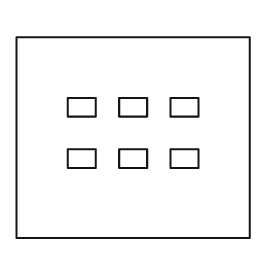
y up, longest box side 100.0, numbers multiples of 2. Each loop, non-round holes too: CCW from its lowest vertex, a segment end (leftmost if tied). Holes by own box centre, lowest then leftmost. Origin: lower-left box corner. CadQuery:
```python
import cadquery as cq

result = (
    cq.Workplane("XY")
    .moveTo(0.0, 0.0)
    .lineTo(100.0, 0.0)
    .lineTo(100.0, 86.0)
    .lineTo(0.0, 86.0)
    .close()
    .moveTo(22.0, 30.0)
    .lineTo(34.0, 30.0)
    .lineTo(34.0, 38.0)
    .lineTo(22.0, 38.0)
    .close()
    .moveTo(44.0, 30.0)
    .lineTo(56.0, 30.0)
    .lineTo(56.0, 38.0)
    .lineTo(44.0, 38.0)
    .close()
    .moveTo(66.0, 30.0)
    .lineTo(78.0, 30.0)
    .lineTo(78.0, 38.0)
    .lineTo(66.0, 38.0)
    .close()
    .moveTo(22.0, 52.0)
    .lineTo(34.0, 52.0)
    .lineTo(34.0, 60.0)
    .lineTo(22.0, 60.0)
    .close()
    .moveTo(44.0, 52.0)
    .lineTo(56.0, 52.0)
    .lineTo(56.0, 60.0)
    .lineTo(44.0, 60.0)
    .close()
    .moveTo(66.0, 52.0)
    .lineTo(78.0, 52.0)
    .lineTo(78.0, 60.0)
    .lineTo(66.0, 60.0)
    .close()
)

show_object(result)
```